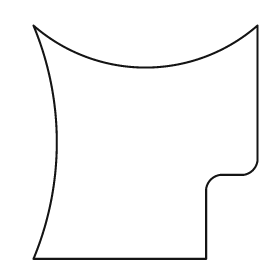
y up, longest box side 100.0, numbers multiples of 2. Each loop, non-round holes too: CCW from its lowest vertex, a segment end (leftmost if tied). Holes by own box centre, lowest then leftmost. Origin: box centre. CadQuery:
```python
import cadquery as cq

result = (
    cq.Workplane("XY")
    .moveTo(-48.0, -50.0)
    .lineTo(26.0, -50.0)
    .lineTo(26.0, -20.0)
    .threePointArc((28.0, -16.0), (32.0, -14.0))
    .lineTo(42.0, -14.0)
    .threePointArc((46.0, -12.0), (48.0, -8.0))
    .lineTo(48.0, 50.0)
    .threePointArc((0.0, 32.0), (-48.0, 50.0))
    .threePointArc((-38.0, 0.0), (-48.0, -50.0))
    .close()
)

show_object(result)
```